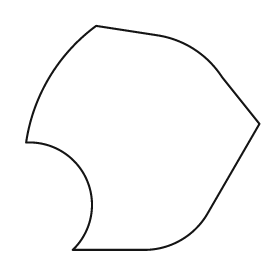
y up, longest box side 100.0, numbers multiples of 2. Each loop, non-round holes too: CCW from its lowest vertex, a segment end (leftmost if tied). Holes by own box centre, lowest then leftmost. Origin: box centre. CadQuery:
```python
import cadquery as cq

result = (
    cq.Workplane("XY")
    .moveTo(-30.0, -48.0)
    .lineTo(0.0, -48.0)
    .threePointArc((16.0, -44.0), (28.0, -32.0))
    .lineTo(50.0, 6.0)
    .lineTo(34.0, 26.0)
    .threePointArc((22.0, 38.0), (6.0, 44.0))
    .lineTo(-20.0, 48.0)
    .threePointArc((-40.0, 26.0), (-50.0, -2.0))
    .threePointArc((-24.0, -18.0), (-30.0, -48.0))
    .close()
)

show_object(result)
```